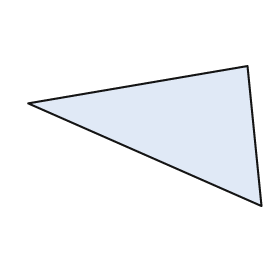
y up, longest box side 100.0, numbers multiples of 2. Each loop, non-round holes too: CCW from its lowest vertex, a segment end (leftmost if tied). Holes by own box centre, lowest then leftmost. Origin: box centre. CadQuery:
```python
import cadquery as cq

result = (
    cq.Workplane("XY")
    .moveTo(50.0, -30.0)
    .lineTo(44.0, 30.0)
    .lineTo(-50.0, 14.0)
    .close()
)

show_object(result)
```